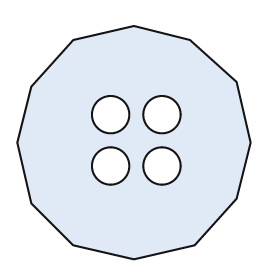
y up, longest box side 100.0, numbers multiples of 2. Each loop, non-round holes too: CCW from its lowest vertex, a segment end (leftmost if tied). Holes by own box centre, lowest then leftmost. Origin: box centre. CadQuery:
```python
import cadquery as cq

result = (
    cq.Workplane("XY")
    .moveTo(0.0, -50.0)
    .lineTo(26.0, -44.0)
    .lineTo(44.0, -24.0)
    .lineTo(50.0, 0.0)
    .lineTo(44.0, 26.0)
    .lineTo(24.0, 44.0)
    .lineTo(0.0, 50.0)
    .lineTo(-26.0, 44.0)
    .lineTo(-44.0, 24.0)
    .lineTo(-50.0, 0.0)
    .lineTo(-44.0, -26.0)
    .lineTo(-26.0, -44.0)
    .close()
    .moveTo(-10.0, -10.0)
    .circle(8.0)
    .moveTo(12.0, -10.0)
    .circle(8.0)
    .moveTo(-10.0, 12.0)
    .circle(8.0)
    .moveTo(12.0, 12.0)
    .circle(8.0)
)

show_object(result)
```